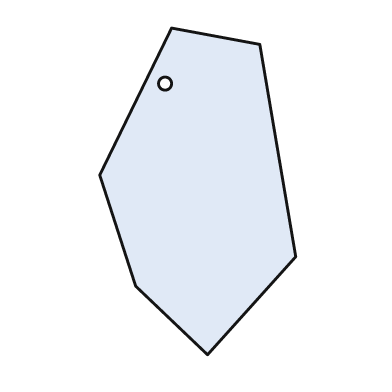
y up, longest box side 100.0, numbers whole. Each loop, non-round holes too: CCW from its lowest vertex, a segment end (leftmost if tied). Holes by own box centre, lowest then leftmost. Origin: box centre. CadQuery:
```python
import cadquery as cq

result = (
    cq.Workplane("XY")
    .moveTo(3.0, -50.0)
    .lineTo(30.0, -20.0)
    .lineTo(19.0, 45.0)
    .lineTo(-8.0, 50.0)
    .lineTo(-30.0, 5.0)
    .lineTo(-19.0, -29.0)
    .close()
    .moveTo(-10.0, 33.0)
    .circle(2.0)
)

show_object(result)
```